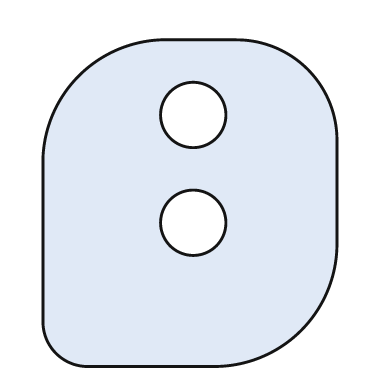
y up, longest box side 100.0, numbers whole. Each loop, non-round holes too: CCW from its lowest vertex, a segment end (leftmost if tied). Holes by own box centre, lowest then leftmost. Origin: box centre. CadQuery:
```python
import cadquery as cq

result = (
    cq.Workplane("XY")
    .moveTo(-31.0, -50.0)
    .lineTo(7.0, -50.0)
    .threePointArc((34.0, -39.0), (45.0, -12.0))
    .lineTo(45.0, 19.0)
    .threePointArc((36.0, 41.0), (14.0, 50.0))
    .lineTo(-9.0, 50.0)
    .threePointArc((-34.0, 39.0), (-45.0, 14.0))
    .lineTo(-45.0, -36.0)
    .threePointArc((-41.0, -46.0), (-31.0, -50.0))
    .close()
    .moveTo(1.0, -6.0)
    .circle(10.0)
    .moveTo(1.0, 27.0)
    .circle(10.0)
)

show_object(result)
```